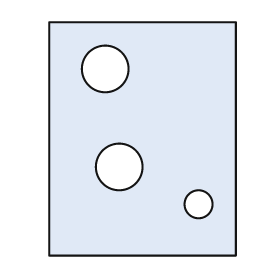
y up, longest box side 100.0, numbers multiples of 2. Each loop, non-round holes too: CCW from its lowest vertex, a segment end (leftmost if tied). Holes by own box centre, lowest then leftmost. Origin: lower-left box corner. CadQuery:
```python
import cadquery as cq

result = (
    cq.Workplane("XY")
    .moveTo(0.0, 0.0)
    .lineTo(80.0, 0.0)
    .lineTo(80.0, 100.0)
    .lineTo(0.0, 100.0)
    .close()
    .moveTo(64.0, 22.0)
    .circle(6.0)
    .moveTo(30.0, 38.0)
    .circle(10.0)
    .moveTo(24.0, 80.0)
    .circle(10.0)
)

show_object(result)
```